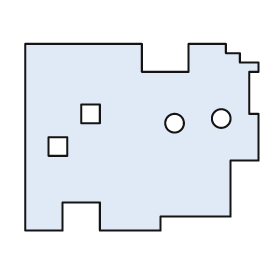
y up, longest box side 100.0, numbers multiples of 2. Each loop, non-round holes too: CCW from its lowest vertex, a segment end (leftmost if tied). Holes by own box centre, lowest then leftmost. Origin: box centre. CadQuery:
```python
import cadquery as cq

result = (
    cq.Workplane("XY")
    .moveTo(-50.0, -40.0)
    .lineTo(-34.0, -40.0)
    .lineTo(-34.0, -28.0)
    .lineTo(-18.0, -28.0)
    .lineTo(-18.0, -40.0)
    .lineTo(8.0, -40.0)
    .lineTo(8.0, -34.0)
    .lineTo(38.0, -34.0)
    .lineTo(38.0, -10.0)
    .lineTo(50.0, -10.0)
    .lineTo(50.0, 10.0)
    .lineTo(46.0, 10.0)
    .lineTo(46.0, 28.0)
    .lineTo(50.0, 28.0)
    .lineTo(50.0, 32.0)
    .lineTo(42.0, 32.0)
    .lineTo(42.0, 36.0)
    .lineTo(36.0, 36.0)
    .lineTo(36.0, 40.0)
    .lineTo(20.0, 40.0)
    .lineTo(20.0, 28.0)
    .lineTo(0.0, 28.0)
    .lineTo(0.0, 40.0)
    .lineTo(-50.0, 40.0)
    .close()
    .moveTo(-40.0, -8.0)
    .lineTo(-32.0, -8.0)
    .lineTo(-32.0, 0.0)
    .lineTo(-40.0, 0.0)
    .close()
    .moveTo(14.0, 6.0)
    .circle(4.0)
    .moveTo(34.0, 8.0)
    .circle(4.0)
    .moveTo(-26.0, 6.0)
    .lineTo(-18.0, 6.0)
    .lineTo(-18.0, 14.0)
    .lineTo(-26.0, 14.0)
    .close()
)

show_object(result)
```